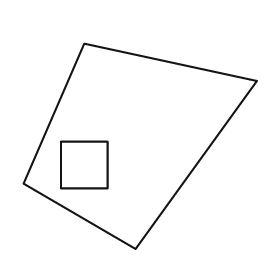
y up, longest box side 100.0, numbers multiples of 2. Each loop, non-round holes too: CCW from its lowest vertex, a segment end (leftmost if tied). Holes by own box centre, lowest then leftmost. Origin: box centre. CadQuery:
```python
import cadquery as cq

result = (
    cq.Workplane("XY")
    .moveTo(-2.0, -44.0)
    .lineTo(50.0, 28.0)
    .lineTo(-24.0, 44.0)
    .lineTo(-50.0, -16.0)
    .close()
    .moveTo(-34.0, -18.0)
    .lineTo(-14.0, -18.0)
    .lineTo(-14.0, 2.0)
    .lineTo(-34.0, 2.0)
    .close()
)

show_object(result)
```